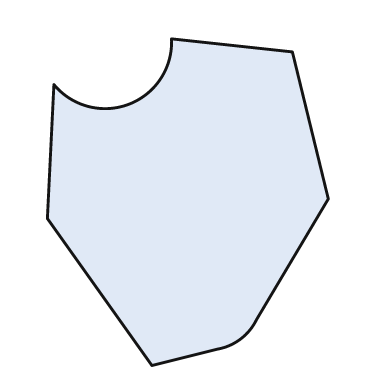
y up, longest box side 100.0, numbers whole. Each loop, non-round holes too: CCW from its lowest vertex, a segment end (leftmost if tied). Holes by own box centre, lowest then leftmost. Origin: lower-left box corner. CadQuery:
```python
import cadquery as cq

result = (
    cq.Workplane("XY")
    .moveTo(32.0, 0.0)
    .lineTo(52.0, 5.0)
    .threePointArc((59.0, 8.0), (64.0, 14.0))
    .lineTo(86.0, 51.0)
    .lineTo(75.0, 96.0)
    .lineTo(38.0, 100.0)
    .threePointArc((25.0, 80.0), (2.0, 86.0))
    .lineTo(0.0, 45.0)
    .close()
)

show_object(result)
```